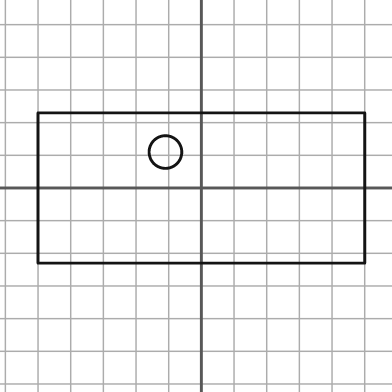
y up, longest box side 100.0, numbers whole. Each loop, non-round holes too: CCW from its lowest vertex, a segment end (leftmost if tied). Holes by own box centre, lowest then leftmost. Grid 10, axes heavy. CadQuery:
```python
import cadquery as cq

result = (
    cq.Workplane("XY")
    .moveTo(-50.0, -23.0)
    .lineTo(50.0, -23.0)
    .lineTo(50.0, 23.0)
    .lineTo(-50.0, 23.0)
    .close()
    .moveTo(-11.0, 11.0)
    .circle(5.0)
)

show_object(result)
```